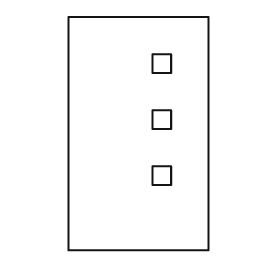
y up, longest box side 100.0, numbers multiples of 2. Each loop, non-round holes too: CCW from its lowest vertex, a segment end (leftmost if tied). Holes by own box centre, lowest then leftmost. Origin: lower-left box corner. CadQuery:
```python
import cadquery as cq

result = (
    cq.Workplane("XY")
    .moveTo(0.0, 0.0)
    .lineTo(60.0, 0.0)
    .lineTo(60.0, 100.0)
    .lineTo(0.0, 100.0)
    .close()
    .moveTo(36.0, 28.0)
    .lineTo(44.0, 28.0)
    .lineTo(44.0, 36.0)
    .lineTo(36.0, 36.0)
    .close()
    .moveTo(36.0, 52.0)
    .lineTo(44.0, 52.0)
    .lineTo(44.0, 60.0)
    .lineTo(36.0, 60.0)
    .close()
    .moveTo(36.0, 76.0)
    .lineTo(44.0, 76.0)
    .lineTo(44.0, 84.0)
    .lineTo(36.0, 84.0)
    .close()
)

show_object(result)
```